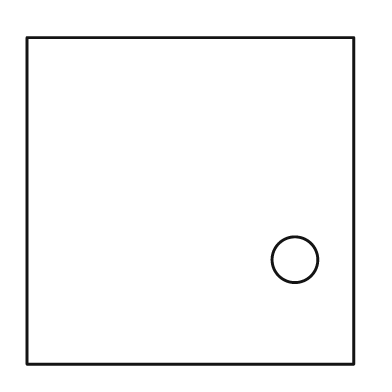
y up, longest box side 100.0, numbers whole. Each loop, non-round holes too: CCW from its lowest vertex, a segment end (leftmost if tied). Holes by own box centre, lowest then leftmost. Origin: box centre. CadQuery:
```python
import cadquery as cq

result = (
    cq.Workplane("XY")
    .moveTo(-50.0, -50.0)
    .lineTo(50.0, -50.0)
    .lineTo(50.0, 50.0)
    .lineTo(-50.0, 50.0)
    .close()
    .moveTo(32.0, -18.0)
    .circle(7.0)
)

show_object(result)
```